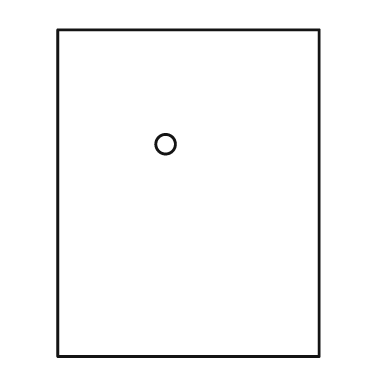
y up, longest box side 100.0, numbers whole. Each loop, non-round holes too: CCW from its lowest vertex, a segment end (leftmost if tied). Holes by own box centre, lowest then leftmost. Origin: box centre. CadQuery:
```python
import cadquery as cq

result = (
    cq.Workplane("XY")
    .moveTo(-40.0, -50.0)
    .lineTo(40.0, -50.0)
    .lineTo(40.0, 50.0)
    .lineTo(-40.0, 50.0)
    .close()
    .moveTo(-7.0, 15.0)
    .circle(3.0)
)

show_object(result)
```